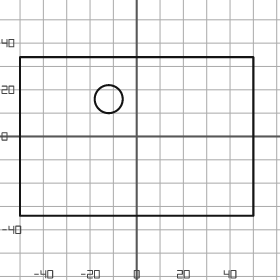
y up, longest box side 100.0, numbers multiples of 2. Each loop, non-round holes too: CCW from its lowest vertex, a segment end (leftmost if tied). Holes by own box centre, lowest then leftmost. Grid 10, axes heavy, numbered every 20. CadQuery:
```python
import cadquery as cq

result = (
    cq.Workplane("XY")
    .moveTo(-50.0, -34.0)
    .lineTo(50.0, -34.0)
    .lineTo(50.0, 34.0)
    .lineTo(-50.0, 34.0)
    .close()
    .moveTo(-12.0, 16.0)
    .circle(6.0)
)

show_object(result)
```